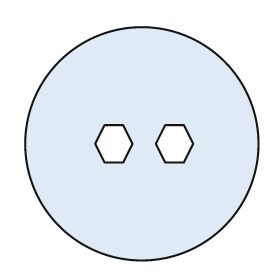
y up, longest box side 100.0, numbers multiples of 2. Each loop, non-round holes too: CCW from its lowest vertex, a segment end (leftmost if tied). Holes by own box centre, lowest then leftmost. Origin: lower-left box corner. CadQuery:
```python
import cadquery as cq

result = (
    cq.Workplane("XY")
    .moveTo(50.0, 50.0)
    .circle(50.0)
    .moveTo(34.0, 42.0)
    .lineTo(42.0, 42.0)
    .lineTo(46.0, 50.0)
    .lineTo(42.0, 58.0)
    .lineTo(34.0, 58.0)
    .lineTo(30.0, 50.0)
    .close()
    .moveTo(60.0, 42.0)
    .lineTo(68.0, 42.0)
    .lineTo(72.0, 50.0)
    .lineTo(68.0, 58.0)
    .lineTo(60.0, 58.0)
    .lineTo(56.0, 50.0)
    .close()
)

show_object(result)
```